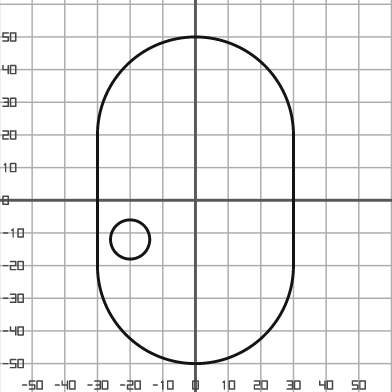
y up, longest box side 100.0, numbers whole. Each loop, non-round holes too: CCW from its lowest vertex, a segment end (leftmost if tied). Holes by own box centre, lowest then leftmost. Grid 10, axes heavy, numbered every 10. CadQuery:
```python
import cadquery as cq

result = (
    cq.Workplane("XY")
    .moveTo(-30.0, -20.0)
    .threePointArc((0.0, -50.0), (30.0, -20.0))
    .lineTo(30.0, 20.0)
    .threePointArc((0.0, 50.0), (-30.0, 20.0))
    .close()
    .moveTo(-20.0, -12.0)
    .circle(6.0)
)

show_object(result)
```